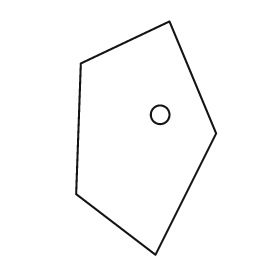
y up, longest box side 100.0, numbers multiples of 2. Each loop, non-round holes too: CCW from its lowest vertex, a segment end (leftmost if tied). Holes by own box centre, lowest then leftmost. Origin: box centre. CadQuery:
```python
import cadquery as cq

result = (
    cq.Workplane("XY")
    .moveTo(4.0, -50.0)
    .lineTo(30.0, 2.0)
    .lineTo(10.0, 50.0)
    .lineTo(-28.0, 32.0)
    .lineTo(-30.0, -24.0)
    .close()
    .moveTo(6.0, 10.0)
    .circle(4.0)
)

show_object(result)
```